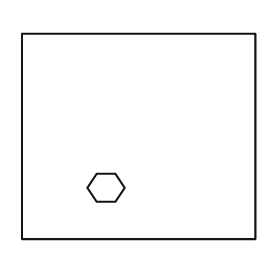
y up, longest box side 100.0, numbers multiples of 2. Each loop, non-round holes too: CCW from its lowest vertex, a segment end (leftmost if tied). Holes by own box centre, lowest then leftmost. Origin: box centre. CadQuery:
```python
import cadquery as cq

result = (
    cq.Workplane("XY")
    .moveTo(-50.0, -44.0)
    .lineTo(50.0, -44.0)
    .lineTo(50.0, 44.0)
    .lineTo(-50.0, 44.0)
    .close()
    .moveTo(-18.0, -28.0)
    .lineTo(-10.0, -28.0)
    .lineTo(-6.0, -22.0)
    .lineTo(-10.0, -16.0)
    .lineTo(-18.0, -16.0)
    .lineTo(-22.0, -22.0)
    .close()
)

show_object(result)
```